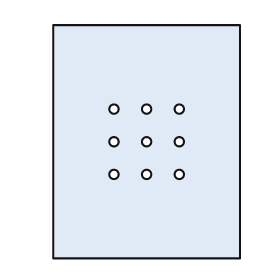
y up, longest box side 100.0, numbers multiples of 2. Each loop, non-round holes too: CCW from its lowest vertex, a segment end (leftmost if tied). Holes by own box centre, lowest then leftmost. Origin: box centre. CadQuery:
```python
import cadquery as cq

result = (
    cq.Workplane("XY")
    .moveTo(-40.0, -50.0)
    .lineTo(40.0, -50.0)
    .lineTo(40.0, 50.0)
    .lineTo(-40.0, 50.0)
    .close()
    .moveTo(-14.0, -14.0)
    .circle(2.0)
    .moveTo(0.0, -14.0)
    .circle(2.0)
    .moveTo(14.0, -14.0)
    .circle(2.0)
    .moveTo(-14.0, 0.0)
    .circle(2.0)
    .moveTo(0.0, 0.0)
    .circle(2.0)
    .moveTo(14.0, 0.0)
    .circle(2.0)
    .moveTo(-14.0, 14.0)
    .circle(2.0)
    .moveTo(0.0, 14.0)
    .circle(2.0)
    .moveTo(14.0, 14.0)
    .circle(2.0)
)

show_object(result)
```